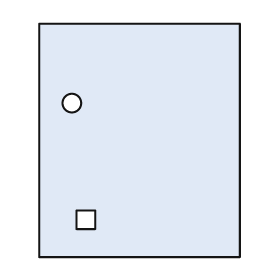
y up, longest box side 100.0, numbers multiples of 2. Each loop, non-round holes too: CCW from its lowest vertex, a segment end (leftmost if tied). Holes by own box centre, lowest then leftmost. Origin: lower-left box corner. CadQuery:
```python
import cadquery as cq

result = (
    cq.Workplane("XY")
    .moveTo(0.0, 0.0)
    .lineTo(86.0, 0.0)
    .lineTo(86.0, 100.0)
    .lineTo(0.0, 100.0)
    .close()
    .moveTo(16.0, 12.0)
    .lineTo(24.0, 12.0)
    .lineTo(24.0, 20.0)
    .lineTo(16.0, 20.0)
    .close()
    .moveTo(14.0, 66.0)
    .circle(4.0)
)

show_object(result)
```